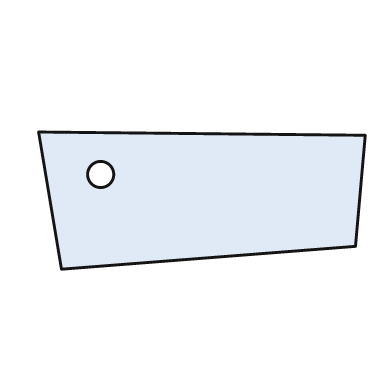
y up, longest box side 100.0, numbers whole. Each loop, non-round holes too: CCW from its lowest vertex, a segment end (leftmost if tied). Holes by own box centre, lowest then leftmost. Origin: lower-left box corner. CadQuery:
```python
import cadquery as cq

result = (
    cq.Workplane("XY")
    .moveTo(7.0, 0.0)
    .lineTo(97.0, 7.0)
    .lineTo(100.0, 41.0)
    .lineTo(0.0, 42.0)
    .close()
    .moveTo(19.0, 29.0)
    .circle(4.0)
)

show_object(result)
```